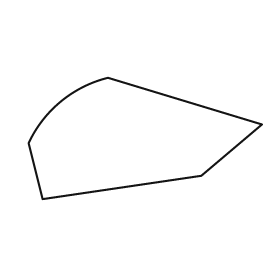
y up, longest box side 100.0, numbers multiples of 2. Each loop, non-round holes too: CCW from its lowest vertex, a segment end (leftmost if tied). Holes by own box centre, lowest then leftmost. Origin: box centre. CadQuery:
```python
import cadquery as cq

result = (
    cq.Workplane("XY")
    .moveTo(-44.0, -26.0)
    .lineTo(24.0, -16.0)
    .lineTo(50.0, 6.0)
    .lineTo(-16.0, 26.0)
    .threePointArc((-36.0, 16.0), (-50.0, -2.0))
    .close()
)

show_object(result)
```